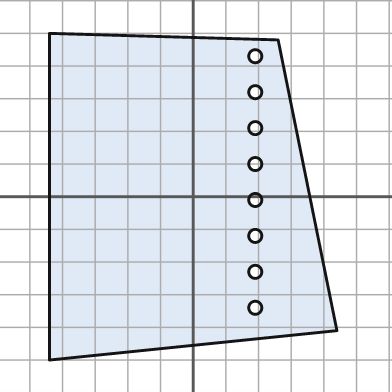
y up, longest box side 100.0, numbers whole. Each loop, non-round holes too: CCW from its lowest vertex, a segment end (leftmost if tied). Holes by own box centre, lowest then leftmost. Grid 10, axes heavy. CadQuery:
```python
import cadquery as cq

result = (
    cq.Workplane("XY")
    .moveTo(-44.0, -50.0)
    .lineTo(44.0, -41.0)
    .lineTo(26.0, 48.0)
    .lineTo(-44.0, 50.0)
    .close()
    .moveTo(19.0, -34.0)
    .circle(2.0)
    .moveTo(19.0, -23.0)
    .circle(2.0)
    .moveTo(19.0, -12.0)
    .circle(2.0)
    .moveTo(19.0, -1.0)
    .circle(2.0)
    .moveTo(19.0, 10.0)
    .circle(2.0)
    .moveTo(19.0, 21.0)
    .circle(2.0)
    .moveTo(19.0, 32.0)
    .circle(2.0)
    .moveTo(19.0, 43.0)
    .circle(2.0)
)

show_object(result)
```